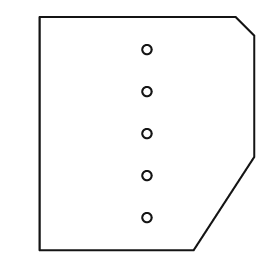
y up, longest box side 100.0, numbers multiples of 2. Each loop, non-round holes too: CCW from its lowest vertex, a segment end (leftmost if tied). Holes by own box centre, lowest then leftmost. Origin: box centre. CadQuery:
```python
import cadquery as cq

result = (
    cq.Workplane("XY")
    .moveTo(-46.0, -50.0)
    .lineTo(20.0, -50.0)
    .lineTo(46.0, -10.0)
    .lineTo(46.0, 42.0)
    .lineTo(38.0, 50.0)
    .lineTo(-46.0, 50.0)
    .close()
    .moveTo(0.0, -36.0)
    .circle(2.0)
    .moveTo(0.0, -18.0)
    .circle(2.0)
    .moveTo(0.0, 0.0)
    .circle(2.0)
    .moveTo(0.0, 18.0)
    .circle(2.0)
    .moveTo(0.0, 36.0)
    .circle(2.0)
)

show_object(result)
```